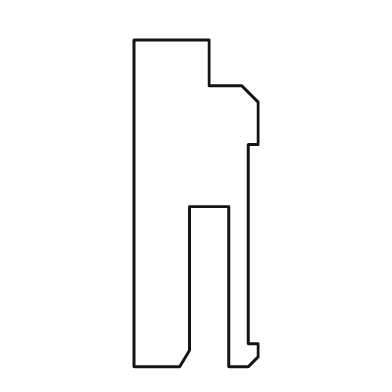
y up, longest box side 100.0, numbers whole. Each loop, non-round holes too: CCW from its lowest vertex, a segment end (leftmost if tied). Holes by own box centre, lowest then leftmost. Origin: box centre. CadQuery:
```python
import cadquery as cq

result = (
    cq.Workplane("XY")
    .moveTo(-19.0, -50.0)
    .lineTo(-5.0, -50.0)
    .lineTo(-2.0, -45.0)
    .lineTo(-2.0, -1.0)
    .lineTo(10.0, -1.0)
    .lineTo(10.0, -50.0)
    .lineTo(16.0, -50.0)
    .lineTo(19.0, -47.0)
    .lineTo(19.0, -43.0)
    .lineTo(16.0, -43.0)
    .lineTo(16.0, 18.0)
    .lineTo(19.0, 18.0)
    .lineTo(19.0, 31.0)
    .lineTo(14.0, 36.0)
    .lineTo(4.0, 36.0)
    .lineTo(4.0, 50.0)
    .lineTo(-19.0, 50.0)
    .close()
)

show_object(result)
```